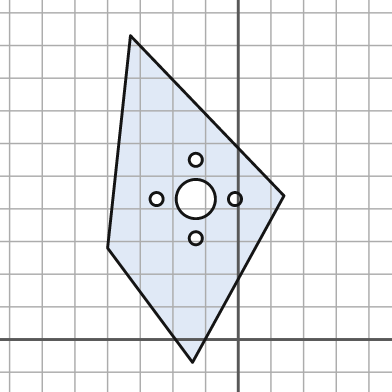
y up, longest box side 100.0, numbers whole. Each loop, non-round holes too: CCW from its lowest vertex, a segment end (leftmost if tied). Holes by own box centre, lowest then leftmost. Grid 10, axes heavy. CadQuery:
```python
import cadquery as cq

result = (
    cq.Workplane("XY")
    .moveTo(-14.0, -7.0)
    .lineTo(14.0, 44.0)
    .lineTo(-33.0, 93.0)
    .lineTo(-40.0, 28.0)
    .close()
    .moveTo(-13.0, 31.0)
    .circle(2.0)
    .moveTo(-25.0, 43.0)
    .circle(2.0)
    .moveTo(-13.0, 43.0)
    .circle(6.0)
    .moveTo(-1.0, 43.0)
    .circle(2.0)
    .moveTo(-13.0, 55.0)
    .circle(2.0)
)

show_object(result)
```